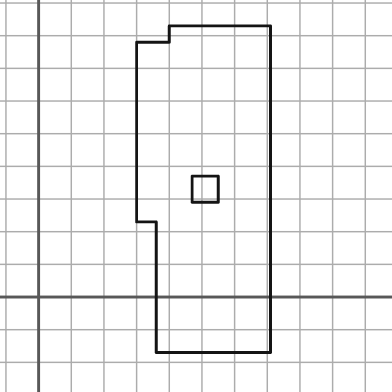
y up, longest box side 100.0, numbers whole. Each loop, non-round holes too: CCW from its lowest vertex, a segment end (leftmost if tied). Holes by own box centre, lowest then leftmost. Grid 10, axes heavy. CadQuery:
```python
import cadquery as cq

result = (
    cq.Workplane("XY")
    .moveTo(36.0, -17.0)
    .lineTo(71.0, -17.0)
    .lineTo(71.0, 83.0)
    .lineTo(40.0, 83.0)
    .lineTo(40.0, 78.0)
    .lineTo(30.0, 78.0)
    .lineTo(30.0, 23.0)
    .lineTo(36.0, 23.0)
    .close()
    .moveTo(47.0, 29.0)
    .lineTo(55.0, 29.0)
    .lineTo(55.0, 37.0)
    .lineTo(47.0, 37.0)
    .close()
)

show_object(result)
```